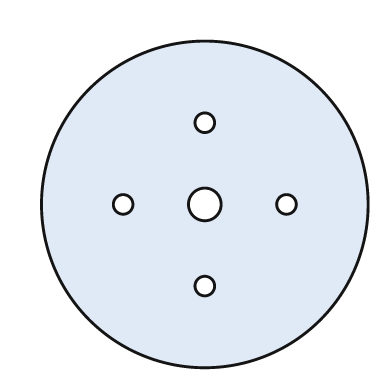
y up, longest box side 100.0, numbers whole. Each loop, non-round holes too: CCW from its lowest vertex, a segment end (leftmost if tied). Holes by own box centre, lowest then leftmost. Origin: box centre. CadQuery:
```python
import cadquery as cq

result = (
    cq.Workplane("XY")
    .moveTo(0.0, 0.0)
    .circle(50.0)
    .moveTo(0.0, -25.0)
    .circle(3.0)
    .moveTo(-25.0, 0.0)
    .circle(3.0)
    .moveTo(0.0, 0.0)
    .circle(5.0)
    .moveTo(25.0, 0.0)
    .circle(3.0)
    .moveTo(0.0, 25.0)
    .circle(3.0)
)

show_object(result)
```